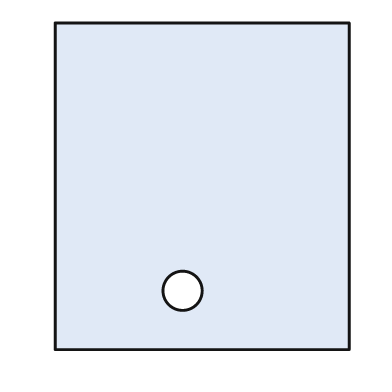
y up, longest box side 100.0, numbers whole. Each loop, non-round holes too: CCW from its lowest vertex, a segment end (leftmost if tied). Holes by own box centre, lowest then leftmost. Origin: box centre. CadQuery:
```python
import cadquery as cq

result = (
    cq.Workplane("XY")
    .moveTo(-45.0, -50.0)
    .lineTo(45.0, -50.0)
    .lineTo(45.0, 50.0)
    .lineTo(-45.0, 50.0)
    .close()
    .moveTo(-6.0, -32.0)
    .circle(6.0)
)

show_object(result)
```